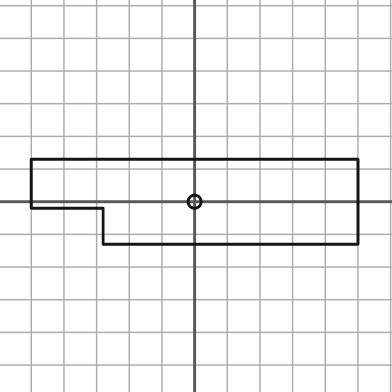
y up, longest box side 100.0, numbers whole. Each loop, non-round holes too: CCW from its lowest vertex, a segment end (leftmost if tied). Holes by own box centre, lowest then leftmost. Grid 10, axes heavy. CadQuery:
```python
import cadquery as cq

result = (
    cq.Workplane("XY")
    .moveTo(-28.0, -13.0)
    .lineTo(50.0, -13.0)
    .lineTo(50.0, 13.0)
    .lineTo(-50.0, 13.0)
    .lineTo(-50.0, -2.0)
    .lineTo(-28.0, -2.0)
    .close()
    .moveTo(0.0, 0.0)
    .circle(2.0)
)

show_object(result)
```